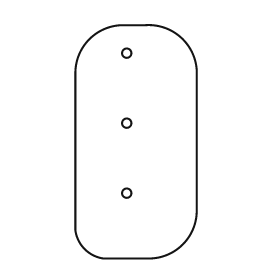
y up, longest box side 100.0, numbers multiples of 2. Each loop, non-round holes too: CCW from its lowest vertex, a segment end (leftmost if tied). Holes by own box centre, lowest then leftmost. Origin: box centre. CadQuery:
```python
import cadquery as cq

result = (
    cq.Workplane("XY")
    .moveTo(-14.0, -50.0)
    .lineTo(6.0, -50.0)
    .threePointArc((20.0, -44.0), (26.0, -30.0))
    .lineTo(26.0, 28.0)
    .threePointArc((20.0, 44.0), (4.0, 50.0))
    .lineTo(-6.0, 50.0)
    .threePointArc((-20.0, 44.0), (-26.0, 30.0))
    .lineTo(-26.0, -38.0)
    .threePointArc((-22.0, -46.0), (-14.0, -50.0))
    .close()
    .moveTo(-4.0, -22.0)
    .circle(2.0)
    .moveTo(-4.0, 8.0)
    .circle(2.0)
    .moveTo(-4.0, 38.0)
    .circle(2.0)
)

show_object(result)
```